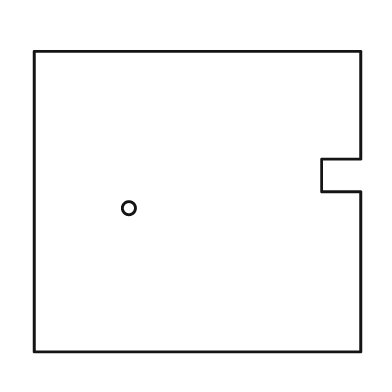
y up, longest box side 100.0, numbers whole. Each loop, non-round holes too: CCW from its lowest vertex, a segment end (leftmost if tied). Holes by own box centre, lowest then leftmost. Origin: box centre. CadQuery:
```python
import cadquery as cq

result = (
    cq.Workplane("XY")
    .moveTo(-50.0, -46.0)
    .lineTo(50.0, -46.0)
    .lineTo(50.0, 3.0)
    .lineTo(38.0, 3.0)
    .lineTo(38.0, 13.0)
    .lineTo(50.0, 13.0)
    .lineTo(50.0, 46.0)
    .lineTo(-50.0, 46.0)
    .close()
    .moveTo(-21.0, -2.0)
    .circle(2.0)
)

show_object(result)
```